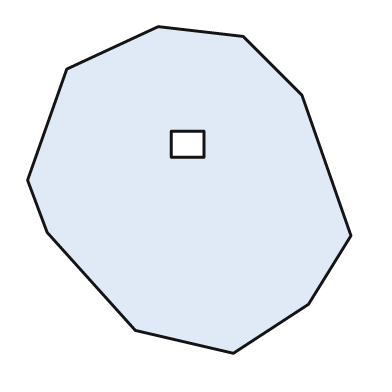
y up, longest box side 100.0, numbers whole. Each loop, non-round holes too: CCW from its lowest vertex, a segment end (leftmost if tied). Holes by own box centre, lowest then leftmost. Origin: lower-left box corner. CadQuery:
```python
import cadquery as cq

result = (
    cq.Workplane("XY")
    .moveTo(63.0, 0.0)
    .lineTo(86.0, 15.0)
    .lineTo(99.0, 36.0)
    .lineTo(84.0, 79.0)
    .lineTo(66.0, 97.0)
    .lineTo(40.0, 100.0)
    .lineTo(12.0, 87.0)
    .lineTo(0.0, 53.0)
    .lineTo(6.0, 37.0)
    .lineTo(33.0, 7.0)
    .close()
    .moveTo(44.0, 60.0)
    .lineTo(54.0, 60.0)
    .lineTo(54.0, 68.0)
    .lineTo(44.0, 68.0)
    .close()
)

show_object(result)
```